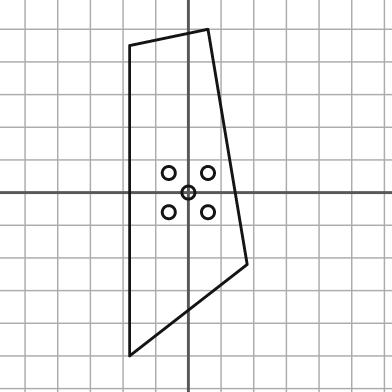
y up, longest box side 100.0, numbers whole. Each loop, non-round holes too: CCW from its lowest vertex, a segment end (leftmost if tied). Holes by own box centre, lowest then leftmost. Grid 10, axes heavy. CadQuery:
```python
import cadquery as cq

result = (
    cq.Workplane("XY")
    .moveTo(-18.0, -50.0)
    .lineTo(18.0, -22.0)
    .lineTo(6.0, 50.0)
    .lineTo(-18.0, 45.0)
    .close()
    .moveTo(-6.0, -6.0)
    .circle(2.0)
    .moveTo(6.0, -6.0)
    .circle(2.0)
    .moveTo(0.0, 0.0)
    .circle(2.0)
    .moveTo(-6.0, 6.0)
    .circle(2.0)
    .moveTo(6.0, 6.0)
    .circle(2.0)
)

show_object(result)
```